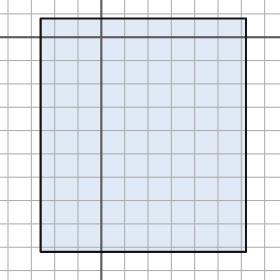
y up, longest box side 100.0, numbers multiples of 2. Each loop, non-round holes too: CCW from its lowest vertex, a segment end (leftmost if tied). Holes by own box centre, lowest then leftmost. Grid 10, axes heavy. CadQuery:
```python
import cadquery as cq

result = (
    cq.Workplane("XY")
    .moveTo(-26.0, -92.0)
    .lineTo(62.0, -92.0)
    .lineTo(62.0, 8.0)
    .lineTo(-26.0, 8.0)
    .close()
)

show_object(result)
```